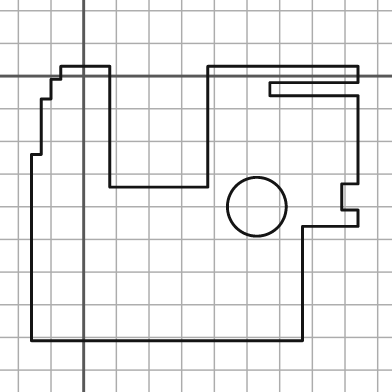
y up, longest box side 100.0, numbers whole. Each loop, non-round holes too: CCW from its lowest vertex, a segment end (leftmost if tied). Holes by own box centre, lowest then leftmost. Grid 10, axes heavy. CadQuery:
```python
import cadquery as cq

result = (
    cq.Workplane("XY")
    .moveTo(-16.0, -81.0)
    .lineTo(67.0, -81.0)
    .lineTo(67.0, -46.0)
    .lineTo(84.0, -46.0)
    .lineTo(84.0, -41.0)
    .lineTo(79.0, -41.0)
    .lineTo(79.0, -33.0)
    .lineTo(84.0, -33.0)
    .lineTo(84.0, -6.0)
    .lineTo(57.0, -6.0)
    .lineTo(57.0, -2.0)
    .lineTo(84.0, -2.0)
    .lineTo(84.0, 3.0)
    .lineTo(38.0, 3.0)
    .lineTo(38.0, -34.0)
    .lineTo(8.0, -34.0)
    .lineTo(8.0, 3.0)
    .lineTo(-7.0, 3.0)
    .lineTo(-7.0, -1.0)
    .lineTo(-10.0, -1.0)
    .lineTo(-10.0, -7.0)
    .lineTo(-13.0, -7.0)
    .lineTo(-13.0, -24.0)
    .lineTo(-16.0, -24.0)
    .close()
    .moveTo(53.0, -40.0)
    .circle(9.0)
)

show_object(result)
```